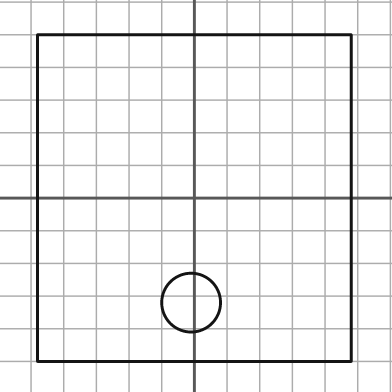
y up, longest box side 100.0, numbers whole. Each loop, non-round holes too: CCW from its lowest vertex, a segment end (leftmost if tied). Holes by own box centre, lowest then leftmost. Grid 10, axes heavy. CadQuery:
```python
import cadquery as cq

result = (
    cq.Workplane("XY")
    .moveTo(-48.0, -50.0)
    .lineTo(48.0, -50.0)
    .lineTo(48.0, 50.0)
    .lineTo(-48.0, 50.0)
    .close()
    .moveTo(-1.0, -32.0)
    .circle(9.0)
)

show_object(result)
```